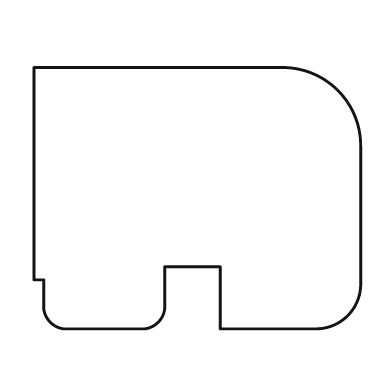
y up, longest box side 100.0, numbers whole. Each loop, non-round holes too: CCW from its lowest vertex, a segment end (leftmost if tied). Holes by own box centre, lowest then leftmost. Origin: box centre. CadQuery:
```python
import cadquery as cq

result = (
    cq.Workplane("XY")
    .moveTo(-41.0, -40.0)
    .lineTo(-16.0, -40.0)
    .threePointArc((-12.0, -38.0), (-10.0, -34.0))
    .lineTo(-10.0, -21.0)
    .lineTo(7.0, -21.0)
    .lineTo(7.0, -40.0)
    .lineTo(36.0, -40.0)
    .threePointArc((46.0, -36.0), (50.0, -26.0))
    .lineTo(50.0, 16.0)
    .threePointArc((43.0, 33.0), (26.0, 40.0))
    .lineTo(-50.0, 40.0)
    .lineTo(-50.0, -25.0)
    .lineTo(-47.0, -25.0)
    .lineTo(-47.0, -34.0)
    .threePointArc((-45.0, -38.0), (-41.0, -40.0))
    .close()
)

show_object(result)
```